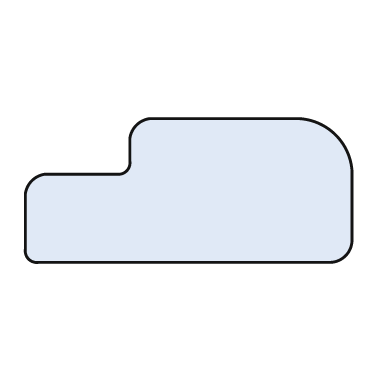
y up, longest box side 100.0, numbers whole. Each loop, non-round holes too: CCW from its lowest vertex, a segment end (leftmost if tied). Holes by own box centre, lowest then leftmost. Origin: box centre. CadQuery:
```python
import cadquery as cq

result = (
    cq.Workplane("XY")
    .moveTo(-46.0, -22.0)
    .lineTo(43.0, -22.0)
    .threePointArc((48.0, -20.0), (50.0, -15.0))
    .lineTo(50.0, 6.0)
    .threePointArc((45.0, 17.0), (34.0, 22.0))
    .lineTo(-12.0, 22.0)
    .threePointArc((-16.0, 20.0), (-18.0, 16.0))
    .lineTo(-18.0, 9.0)
    .threePointArc((-19.0, 6.0), (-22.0, 5.0))
    .lineTo(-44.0, 5.0)
    .threePointArc((-48.0, 3.0), (-50.0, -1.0))
    .lineTo(-50.0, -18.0)
    .threePointArc((-49.0, -21.0), (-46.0, -22.0))
    .close()
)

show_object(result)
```